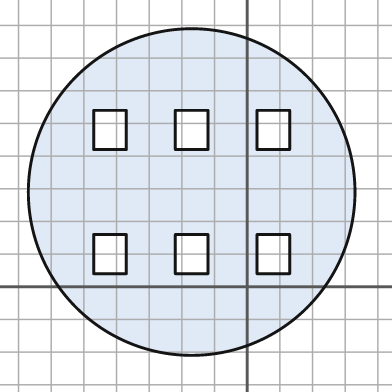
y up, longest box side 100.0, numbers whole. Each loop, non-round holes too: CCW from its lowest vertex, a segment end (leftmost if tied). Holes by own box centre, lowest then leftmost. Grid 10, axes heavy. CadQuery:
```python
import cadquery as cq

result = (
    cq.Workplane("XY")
    .moveTo(-17.0, 29.0)
    .circle(50.0)
    .moveTo(-47.0, 4.0)
    .lineTo(-37.0, 4.0)
    .lineTo(-37.0, 16.0)
    .lineTo(-47.0, 16.0)
    .close()
    .moveTo(-22.0, 4.0)
    .lineTo(-12.0, 4.0)
    .lineTo(-12.0, 16.0)
    .lineTo(-22.0, 16.0)
    .close()
    .moveTo(3.0, 4.0)
    .lineTo(13.0, 4.0)
    .lineTo(13.0, 16.0)
    .lineTo(3.0, 16.0)
    .close()
    .moveTo(-47.0, 42.0)
    .lineTo(-37.0, 42.0)
    .lineTo(-37.0, 54.0)
    .lineTo(-47.0, 54.0)
    .close()
    .moveTo(-22.0, 42.0)
    .lineTo(-12.0, 42.0)
    .lineTo(-12.0, 54.0)
    .lineTo(-22.0, 54.0)
    .close()
    .moveTo(3.0, 42.0)
    .lineTo(13.0, 42.0)
    .lineTo(13.0, 54.0)
    .lineTo(3.0, 54.0)
    .close()
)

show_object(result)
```